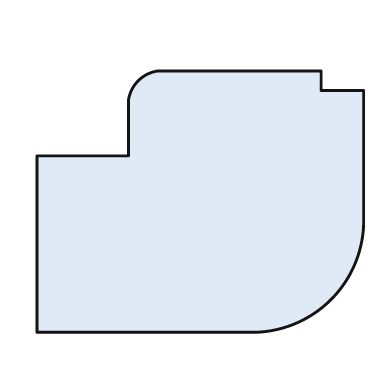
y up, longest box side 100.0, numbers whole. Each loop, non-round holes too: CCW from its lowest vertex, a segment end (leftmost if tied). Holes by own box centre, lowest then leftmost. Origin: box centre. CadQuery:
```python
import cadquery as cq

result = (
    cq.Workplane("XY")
    .moveTo(-50.0, -40.0)
    .lineTo(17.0, -40.0)
    .threePointArc((40.0, -30.0), (50.0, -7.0))
    .lineTo(50.0, 34.0)
    .lineTo(37.0, 34.0)
    .lineTo(37.0, 40.0)
    .lineTo(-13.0, 40.0)
    .threePointArc((-19.0, 37.0), (-22.0, 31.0))
    .lineTo(-22.0, 14.0)
    .lineTo(-50.0, 14.0)
    .close()
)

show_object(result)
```